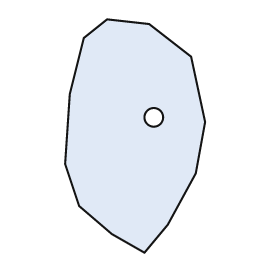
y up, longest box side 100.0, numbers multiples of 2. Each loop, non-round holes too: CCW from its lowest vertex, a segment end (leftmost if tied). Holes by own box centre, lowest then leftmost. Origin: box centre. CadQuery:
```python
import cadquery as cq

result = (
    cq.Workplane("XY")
    .moveTo(4.0, -50.0)
    .lineTo(14.0, -38.0)
    .lineTo(26.0, -16.0)
    .lineTo(30.0, 6.0)
    .lineTo(24.0, 34.0)
    .lineTo(6.0, 48.0)
    .lineTo(-12.0, 50.0)
    .lineTo(-22.0, 42.0)
    .lineTo(-28.0, 18.0)
    .lineTo(-30.0, -12.0)
    .lineTo(-24.0, -30.0)
    .lineTo(-10.0, -42.0)
    .close()
    .moveTo(8.0, 8.0)
    .circle(4.0)
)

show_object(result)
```